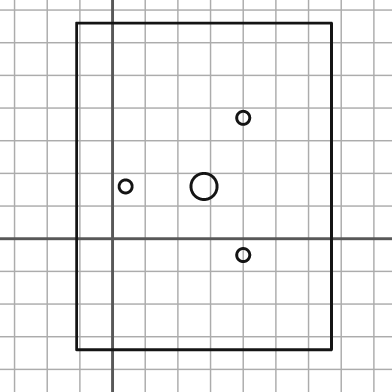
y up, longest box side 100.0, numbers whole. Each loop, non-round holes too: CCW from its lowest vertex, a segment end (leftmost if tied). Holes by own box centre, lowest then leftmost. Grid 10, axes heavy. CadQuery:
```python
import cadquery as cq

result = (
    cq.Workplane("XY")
    .moveTo(-11.0, -34.0)
    .lineTo(67.0, -34.0)
    .lineTo(67.0, 66.0)
    .lineTo(-11.0, 66.0)
    .close()
    .moveTo(40.0, -5.0)
    .circle(2.0)
    .moveTo(4.0, 16.0)
    .circle(2.0)
    .moveTo(28.0, 16.0)
    .circle(4.0)
    .moveTo(40.0, 37.0)
    .circle(2.0)
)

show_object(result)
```